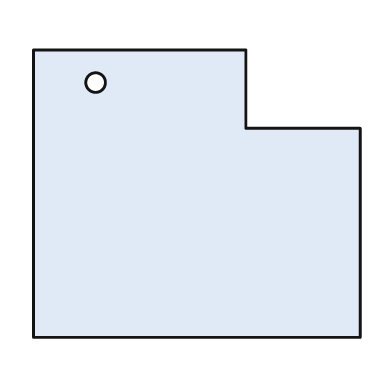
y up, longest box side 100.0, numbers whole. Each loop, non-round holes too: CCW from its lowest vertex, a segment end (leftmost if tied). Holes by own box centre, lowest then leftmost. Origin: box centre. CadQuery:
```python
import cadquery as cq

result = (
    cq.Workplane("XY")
    .moveTo(-50.0, -44.0)
    .lineTo(50.0, -44.0)
    .lineTo(50.0, 20.0)
    .lineTo(15.0, 20.0)
    .lineTo(15.0, 44.0)
    .lineTo(-50.0, 44.0)
    .close()
    .moveTo(-31.0, 34.0)
    .circle(3.0)
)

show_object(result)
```